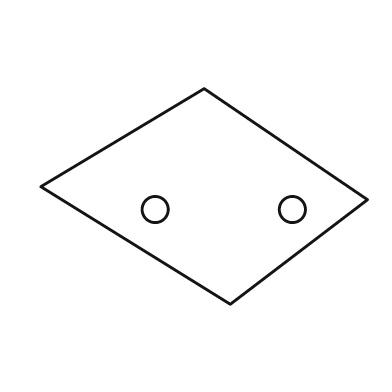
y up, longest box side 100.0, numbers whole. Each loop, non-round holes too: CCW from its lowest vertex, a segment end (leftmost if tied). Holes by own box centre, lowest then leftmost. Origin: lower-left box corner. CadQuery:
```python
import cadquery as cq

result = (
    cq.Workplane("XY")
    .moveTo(58.0, 0.0)
    .lineTo(100.0, 32.0)
    .lineTo(50.0, 66.0)
    .lineTo(0.0, 36.0)
    .close()
    .moveTo(35.0, 29.0)
    .circle(4.0)
    .moveTo(77.0, 29.0)
    .circle(4.0)
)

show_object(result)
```